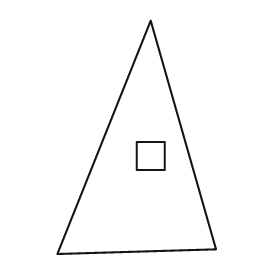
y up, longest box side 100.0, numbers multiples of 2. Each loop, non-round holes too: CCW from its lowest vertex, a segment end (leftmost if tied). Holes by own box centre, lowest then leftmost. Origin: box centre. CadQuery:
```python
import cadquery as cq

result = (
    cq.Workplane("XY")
    .moveTo(-34.0, -50.0)
    .lineTo(34.0, -48.0)
    .lineTo(6.0, 50.0)
    .close()
    .moveTo(0.0, -14.0)
    .lineTo(12.0, -14.0)
    .lineTo(12.0, -2.0)
    .lineTo(0.0, -2.0)
    .close()
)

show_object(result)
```